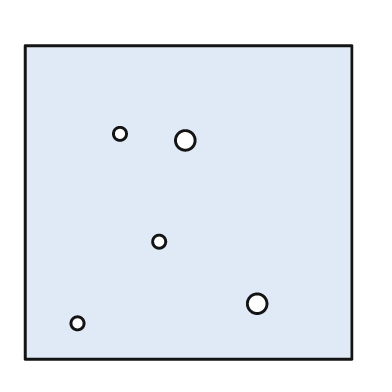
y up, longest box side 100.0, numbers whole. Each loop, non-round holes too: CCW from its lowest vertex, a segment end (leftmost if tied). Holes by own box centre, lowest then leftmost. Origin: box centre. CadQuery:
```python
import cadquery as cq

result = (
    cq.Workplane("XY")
    .moveTo(-50.0, -48.0)
    .lineTo(50.0, -48.0)
    .lineTo(50.0, 48.0)
    .lineTo(-50.0, 48.0)
    .close()
    .moveTo(-34.0, -37.0)
    .circle(2.0)
    .moveTo(21.0, -31.0)
    .circle(3.0)
    .moveTo(-9.0, -12.0)
    .circle(2.0)
    .moveTo(-1.0, 19.0)
    .circle(3.0)
    .moveTo(-21.0, 21.0)
    .circle(2.0)
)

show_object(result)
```